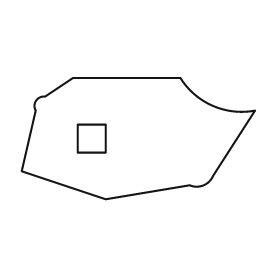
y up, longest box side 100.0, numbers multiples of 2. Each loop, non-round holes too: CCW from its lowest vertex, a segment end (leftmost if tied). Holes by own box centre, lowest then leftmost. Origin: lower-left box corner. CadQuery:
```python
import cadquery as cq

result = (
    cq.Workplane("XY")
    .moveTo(36.0, 0.0)
    .lineTo(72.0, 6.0)
    .threePointArc((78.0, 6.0), (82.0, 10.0))
    .lineTo(100.0, 38.0)
    .threePointArc((82.0, 40.0), (68.0, 52.0))
    .lineTo(22.0, 52.0)
    .lineTo(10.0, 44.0)
    .threePointArc((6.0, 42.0), (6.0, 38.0))
    .lineTo(0.0, 12.0)
    .close()
    .moveTo(24.0, 20.0)
    .lineTo(36.0, 20.0)
    .lineTo(36.0, 32.0)
    .lineTo(24.0, 32.0)
    .close()
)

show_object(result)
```